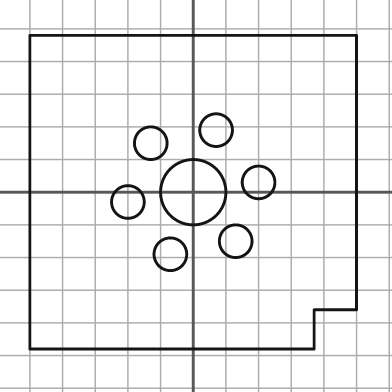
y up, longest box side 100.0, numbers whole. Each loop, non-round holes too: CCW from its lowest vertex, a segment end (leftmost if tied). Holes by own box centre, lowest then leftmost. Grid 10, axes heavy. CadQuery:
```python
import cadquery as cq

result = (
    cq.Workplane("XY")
    .moveTo(-50.0, -48.0)
    .lineTo(37.0, -48.0)
    .lineTo(37.0, -36.0)
    .lineTo(50.0, -36.0)
    .lineTo(50.0, 48.0)
    .lineTo(-50.0, 48.0)
    .close()
    .moveTo(-7.0, -19.0)
    .circle(5.0)
    .moveTo(13.0, -15.0)
    .circle(5.0)
    .moveTo(-20.0, -3.0)
    .circle(5.0)
    .moveTo(0.0, 0.0)
    .circle(10.0)
    .moveTo(20.0, 3.0)
    .circle(5.0)
    .moveTo(-13.0, 15.0)
    .circle(5.0)
    .moveTo(7.0, 19.0)
    .circle(5.0)
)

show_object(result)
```